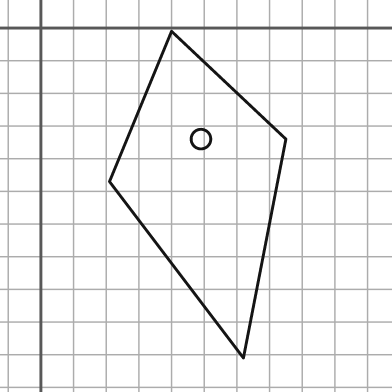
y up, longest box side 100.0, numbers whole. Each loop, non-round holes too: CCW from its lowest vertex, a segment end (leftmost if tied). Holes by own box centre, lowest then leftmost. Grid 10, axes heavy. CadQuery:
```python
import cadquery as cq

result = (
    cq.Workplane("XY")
    .moveTo(62.0, -101.0)
    .lineTo(75.0, -34.0)
    .lineTo(40.0, -1.0)
    .lineTo(21.0, -47.0)
    .close()
    .moveTo(49.0, -34.0)
    .circle(3.0)
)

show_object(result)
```